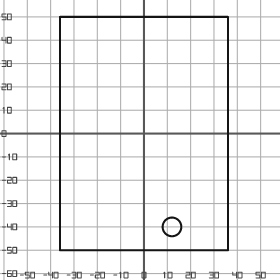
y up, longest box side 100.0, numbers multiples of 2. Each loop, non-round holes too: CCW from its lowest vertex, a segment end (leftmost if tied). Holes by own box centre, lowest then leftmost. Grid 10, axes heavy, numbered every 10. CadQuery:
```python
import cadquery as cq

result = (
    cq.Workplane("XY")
    .moveTo(-36.0, -50.0)
    .lineTo(36.0, -50.0)
    .lineTo(36.0, 50.0)
    .lineTo(-36.0, 50.0)
    .close()
    .moveTo(12.0, -40.0)
    .circle(4.0)
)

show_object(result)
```